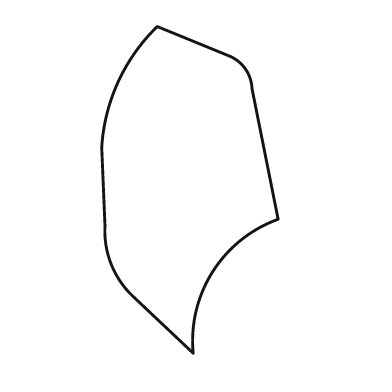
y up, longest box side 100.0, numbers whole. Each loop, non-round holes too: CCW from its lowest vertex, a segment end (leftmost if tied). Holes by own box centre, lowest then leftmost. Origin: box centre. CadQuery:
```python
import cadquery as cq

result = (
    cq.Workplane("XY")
    .moveTo(1.0, -50.0)
    .threePointArc((7.0, -25.0), (27.0, -9.0))
    .lineTo(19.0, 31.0)
    .threePointArc((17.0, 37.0), (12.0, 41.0))
    .lineTo(-10.0, 50.0)
    .threePointArc((-22.0, 33.0), (-27.0, 13.0))
    .lineTo(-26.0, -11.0)
    .threePointArc((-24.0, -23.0), (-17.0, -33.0))
    .close()
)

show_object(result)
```